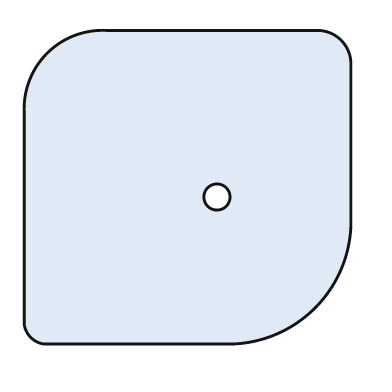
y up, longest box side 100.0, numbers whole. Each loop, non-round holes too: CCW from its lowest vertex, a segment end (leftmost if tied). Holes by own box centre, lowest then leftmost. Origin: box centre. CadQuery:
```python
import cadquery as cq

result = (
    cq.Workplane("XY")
    .moveTo(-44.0, -48.0)
    .lineTo(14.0, -48.0)
    .threePointArc((39.0, -37.0), (50.0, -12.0))
    .lineTo(50.0, 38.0)
    .threePointArc((47.0, 45.0), (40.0, 48.0))
    .lineTo(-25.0, 48.0)
    .threePointArc((-43.0, 41.0), (-50.0, 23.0))
    .lineTo(-50.0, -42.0)
    .threePointArc((-48.0, -46.0), (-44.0, -48.0))
    .close()
    .moveTo(9.0, -3.0)
    .circle(4.0)
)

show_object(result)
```